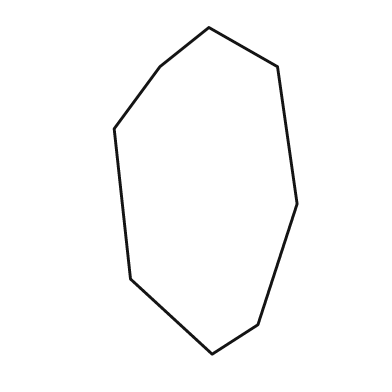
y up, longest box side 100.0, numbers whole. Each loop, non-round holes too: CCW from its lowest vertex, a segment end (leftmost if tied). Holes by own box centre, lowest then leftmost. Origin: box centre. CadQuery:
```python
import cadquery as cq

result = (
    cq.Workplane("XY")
    .moveTo(2.0, -50.0)
    .lineTo(16.0, -41.0)
    .lineTo(28.0, -4.0)
    .lineTo(22.0, 38.0)
    .lineTo(1.0, 50.0)
    .lineTo(-14.0, 38.0)
    .lineTo(-28.0, 19.0)
    .lineTo(-23.0, -27.0)
    .close()
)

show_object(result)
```